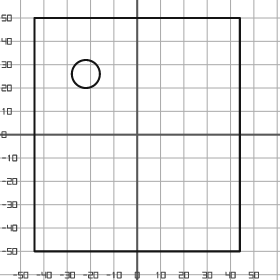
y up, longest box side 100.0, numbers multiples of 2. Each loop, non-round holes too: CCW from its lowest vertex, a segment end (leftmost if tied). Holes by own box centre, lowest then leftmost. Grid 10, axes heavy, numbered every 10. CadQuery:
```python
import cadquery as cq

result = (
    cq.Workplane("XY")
    .moveTo(-44.0, -50.0)
    .lineTo(44.0, -50.0)
    .lineTo(44.0, 50.0)
    .lineTo(-44.0, 50.0)
    .close()
    .moveTo(-22.0, 26.0)
    .circle(6.0)
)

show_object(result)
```